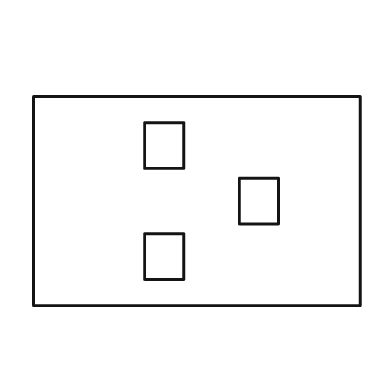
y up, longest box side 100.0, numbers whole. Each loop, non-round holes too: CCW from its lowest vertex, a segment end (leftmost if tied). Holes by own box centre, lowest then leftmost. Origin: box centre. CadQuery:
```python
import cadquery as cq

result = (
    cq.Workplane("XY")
    .moveTo(-50.0, -32.0)
    .lineTo(50.0, -32.0)
    .lineTo(50.0, 32.0)
    .lineTo(-50.0, 32.0)
    .close()
    .moveTo(-16.0, -24.0)
    .lineTo(-4.0, -24.0)
    .lineTo(-4.0, -10.0)
    .lineTo(-16.0, -10.0)
    .close()
    .moveTo(13.0, -7.0)
    .lineTo(25.0, -7.0)
    .lineTo(25.0, 7.0)
    .lineTo(13.0, 7.0)
    .close()
    .moveTo(-16.0, 10.0)
    .lineTo(-4.0, 10.0)
    .lineTo(-4.0, 24.0)
    .lineTo(-16.0, 24.0)
    .close()
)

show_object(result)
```